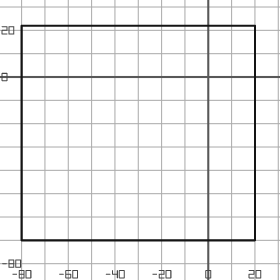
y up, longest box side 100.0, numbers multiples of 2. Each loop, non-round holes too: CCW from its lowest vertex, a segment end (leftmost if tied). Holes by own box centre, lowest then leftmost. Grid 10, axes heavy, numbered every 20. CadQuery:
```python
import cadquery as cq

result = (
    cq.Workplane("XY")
    .moveTo(-80.0, -70.0)
    .lineTo(20.0, -70.0)
    .lineTo(20.0, 22.0)
    .lineTo(-80.0, 22.0)
    .close()
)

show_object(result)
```